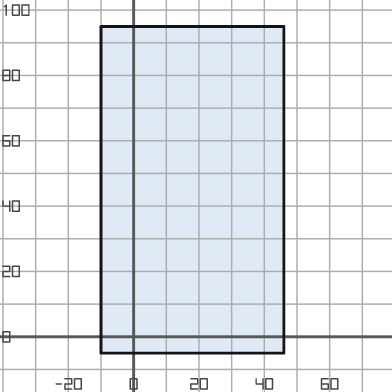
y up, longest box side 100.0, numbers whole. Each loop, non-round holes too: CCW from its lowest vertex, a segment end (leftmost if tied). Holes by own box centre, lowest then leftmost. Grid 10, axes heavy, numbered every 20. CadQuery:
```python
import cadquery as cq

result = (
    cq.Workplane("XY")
    .moveTo(-10.0, -5.0)
    .lineTo(46.0, -5.0)
    .lineTo(46.0, 95.0)
    .lineTo(-10.0, 95.0)
    .close()
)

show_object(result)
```